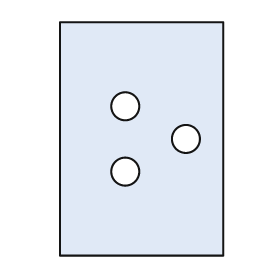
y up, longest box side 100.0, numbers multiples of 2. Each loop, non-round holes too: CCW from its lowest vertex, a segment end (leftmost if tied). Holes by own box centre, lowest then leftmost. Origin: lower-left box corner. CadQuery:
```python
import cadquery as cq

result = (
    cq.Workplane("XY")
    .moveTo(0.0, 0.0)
    .lineTo(70.0, 0.0)
    .lineTo(70.0, 100.0)
    .lineTo(0.0, 100.0)
    .close()
    .moveTo(28.0, 36.0)
    .circle(6.0)
    .moveTo(54.0, 50.0)
    .circle(6.0)
    .moveTo(28.0, 64.0)
    .circle(6.0)
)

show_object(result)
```